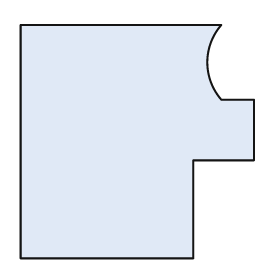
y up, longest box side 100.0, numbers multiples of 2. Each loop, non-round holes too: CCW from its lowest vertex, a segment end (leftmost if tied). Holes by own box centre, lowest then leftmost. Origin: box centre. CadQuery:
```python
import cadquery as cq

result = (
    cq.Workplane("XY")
    .moveTo(-50.0, -50.0)
    .lineTo(24.0, -50.0)
    .lineTo(24.0, -8.0)
    .lineTo(50.0, -8.0)
    .lineTo(50.0, 18.0)
    .lineTo(36.0, 18.0)
    .threePointArc((30.0, 34.0), (36.0, 50.0))
    .lineTo(-50.0, 50.0)
    .close()
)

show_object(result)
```